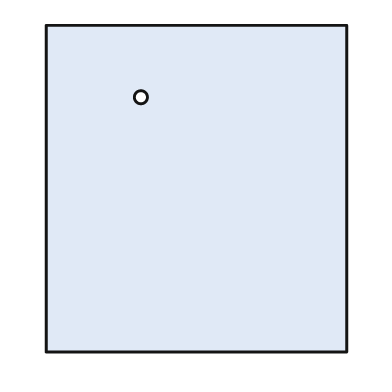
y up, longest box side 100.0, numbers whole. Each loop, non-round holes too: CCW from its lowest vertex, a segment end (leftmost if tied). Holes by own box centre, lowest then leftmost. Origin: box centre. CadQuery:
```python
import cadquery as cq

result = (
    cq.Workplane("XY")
    .moveTo(-46.0, -50.0)
    .lineTo(46.0, -50.0)
    .lineTo(46.0, 50.0)
    .lineTo(-46.0, 50.0)
    .close()
    .moveTo(-17.0, 28.0)
    .circle(2.0)
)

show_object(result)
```